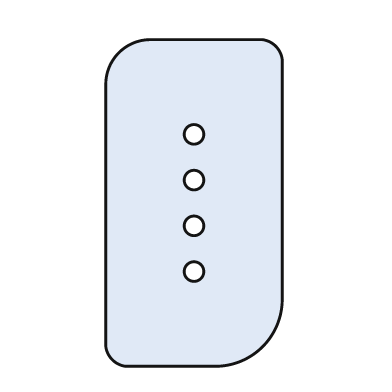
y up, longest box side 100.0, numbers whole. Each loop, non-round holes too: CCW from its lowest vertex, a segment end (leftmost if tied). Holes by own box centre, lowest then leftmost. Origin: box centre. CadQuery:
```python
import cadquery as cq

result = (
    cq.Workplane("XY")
    .moveTo(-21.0, -50.0)
    .lineTo(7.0, -50.0)
    .threePointArc((21.0, -44.0), (27.0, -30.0))
    .lineTo(27.0, 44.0)
    .threePointArc((25.0, 48.0), (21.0, 50.0))
    .lineTo(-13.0, 50.0)
    .threePointArc((-23.0, 46.0), (-27.0, 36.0))
    .lineTo(-27.0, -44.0)
    .threePointArc((-25.0, -48.0), (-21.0, -50.0))
    .close()
    .moveTo(0.0, -21.0)
    .circle(3.0)
    .moveTo(0.0, -7.0)
    .circle(3.0)
    .moveTo(0.0, 7.0)
    .circle(3.0)
    .moveTo(0.0, 21.0)
    .circle(3.0)
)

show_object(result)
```